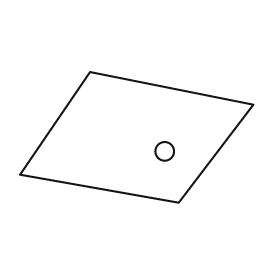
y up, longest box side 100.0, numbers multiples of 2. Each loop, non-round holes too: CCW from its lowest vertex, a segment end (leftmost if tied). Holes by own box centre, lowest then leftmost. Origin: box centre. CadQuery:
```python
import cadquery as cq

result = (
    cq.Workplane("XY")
    .moveTo(18.0, -28.0)
    .lineTo(50.0, 14.0)
    .lineTo(-20.0, 28.0)
    .lineTo(-50.0, -16.0)
    .close()
    .moveTo(12.0, -6.0)
    .circle(4.0)
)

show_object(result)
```